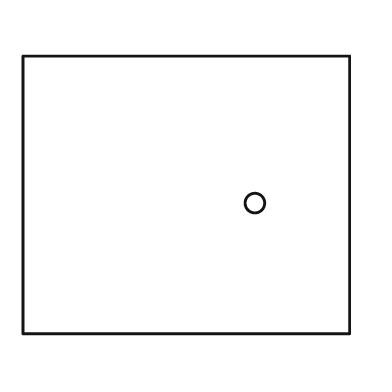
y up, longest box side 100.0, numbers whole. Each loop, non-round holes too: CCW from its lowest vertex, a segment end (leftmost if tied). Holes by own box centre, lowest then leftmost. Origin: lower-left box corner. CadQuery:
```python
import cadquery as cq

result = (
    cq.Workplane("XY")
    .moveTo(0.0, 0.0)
    .lineTo(100.0, 0.0)
    .lineTo(100.0, 85.0)
    .lineTo(0.0, 85.0)
    .close()
    .moveTo(71.0, 40.0)
    .circle(3.0)
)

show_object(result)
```